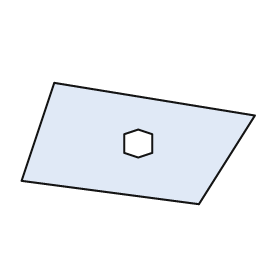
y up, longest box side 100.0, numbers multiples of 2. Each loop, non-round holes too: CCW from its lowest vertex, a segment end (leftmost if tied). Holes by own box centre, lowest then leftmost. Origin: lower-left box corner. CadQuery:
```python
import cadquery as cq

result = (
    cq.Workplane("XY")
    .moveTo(76.0, 0.0)
    .lineTo(100.0, 38.0)
    .lineTo(14.0, 52.0)
    .lineTo(0.0, 10.0)
    .close()
    .moveTo(50.0, 20.0)
    .lineTo(56.0, 22.0)
    .lineTo(56.0, 30.0)
    .lineTo(50.0, 32.0)
    .lineTo(44.0, 30.0)
    .lineTo(44.0, 22.0)
    .close()
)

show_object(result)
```